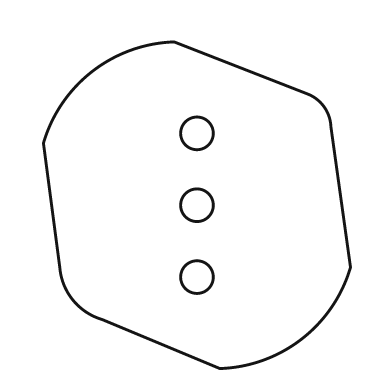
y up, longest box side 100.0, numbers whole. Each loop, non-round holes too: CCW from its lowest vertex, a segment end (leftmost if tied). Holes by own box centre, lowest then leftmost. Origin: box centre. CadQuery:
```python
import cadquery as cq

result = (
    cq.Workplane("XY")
    .moveTo(7.0, -50.0)
    .threePointArc((32.0, -41.0), (47.0, -19.0))
    .lineTo(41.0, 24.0)
    .threePointArc((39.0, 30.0), (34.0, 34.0))
    .lineTo(-7.0, 50.0)
    .threePointArc((-32.0, 41.0), (-47.0, 19.0))
    .lineTo(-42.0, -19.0)
    .threePointArc((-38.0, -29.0), (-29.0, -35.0))
    .close()
    .moveTo(0.0, -22.0)
    .circle(5.0)
    .moveTo(0.0, 0.0)
    .circle(5.0)
    .moveTo(0.0, 22.0)
    .circle(5.0)
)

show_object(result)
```